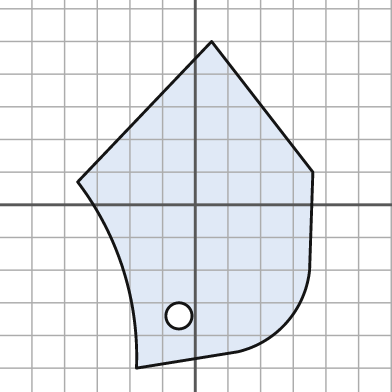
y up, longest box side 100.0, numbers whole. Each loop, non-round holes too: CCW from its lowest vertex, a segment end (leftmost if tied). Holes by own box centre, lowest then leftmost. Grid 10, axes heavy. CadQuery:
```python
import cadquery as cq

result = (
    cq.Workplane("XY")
    .moveTo(-18.0, -50.0)
    .lineTo(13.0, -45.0)
    .threePointArc((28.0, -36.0), (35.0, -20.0))
    .lineTo(36.0, 10.0)
    .lineTo(5.0, 50.0)
    .lineTo(-36.0, 7.0)
    .threePointArc((-22.0, -20.0), (-18.0, -50.0))
    .close()
    .moveTo(-5.0, -34.0)
    .circle(4.0)
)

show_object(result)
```